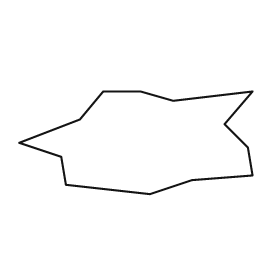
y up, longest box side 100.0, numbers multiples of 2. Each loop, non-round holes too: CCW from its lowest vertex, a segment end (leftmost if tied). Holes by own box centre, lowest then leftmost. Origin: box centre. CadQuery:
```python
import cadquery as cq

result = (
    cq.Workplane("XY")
    .moveTo(6.0, -22.0)
    .lineTo(24.0, -16.0)
    .lineTo(50.0, -14.0)
    .lineTo(48.0, -2.0)
    .lineTo(38.0, 8.0)
    .lineTo(50.0, 22.0)
    .lineTo(16.0, 18.0)
    .lineTo(2.0, 22.0)
    .lineTo(-14.0, 22.0)
    .lineTo(-24.0, 10.0)
    .lineTo(-50.0, 0.0)
    .lineTo(-32.0, -6.0)
    .lineTo(-30.0, -18.0)
    .close()
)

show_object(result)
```